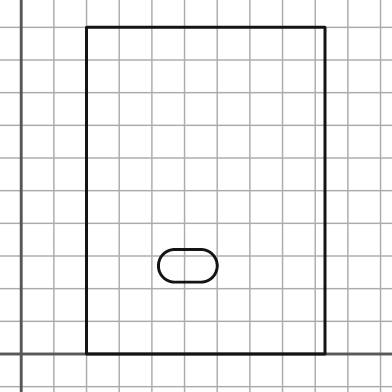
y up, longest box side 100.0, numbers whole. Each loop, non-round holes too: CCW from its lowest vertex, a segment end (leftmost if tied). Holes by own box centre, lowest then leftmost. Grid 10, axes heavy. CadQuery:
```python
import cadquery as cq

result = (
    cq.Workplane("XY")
    .moveTo(20.0, 0.0)
    .lineTo(93.0, 0.0)
    .lineTo(93.0, 100.0)
    .lineTo(20.0, 100.0)
    .close()
    .moveTo(47.0, 22.0)
    .lineTo(55.0, 22.0)
    .threePointArc((60.0, 27.0), (55.0, 32.0))
    .lineTo(47.0, 32.0)
    .threePointArc((42.0, 27.0), (47.0, 22.0))
    .close()
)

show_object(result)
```